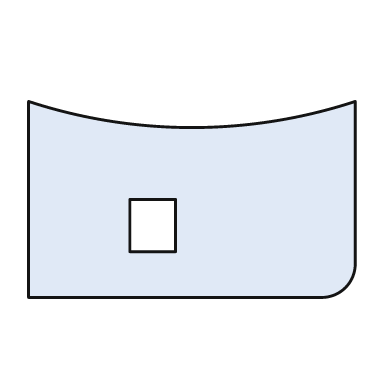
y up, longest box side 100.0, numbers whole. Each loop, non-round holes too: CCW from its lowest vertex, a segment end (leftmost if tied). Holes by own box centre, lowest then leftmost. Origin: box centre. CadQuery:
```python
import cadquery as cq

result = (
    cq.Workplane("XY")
    .moveTo(-50.0, -30.0)
    .lineTo(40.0, -30.0)
    .threePointArc((47.0, -27.0), (50.0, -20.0))
    .lineTo(50.0, 30.0)
    .threePointArc((0.0, 22.0), (-50.0, 30.0))
    .close()
    .moveTo(-19.0, -16.0)
    .lineTo(-5.0, -16.0)
    .lineTo(-5.0, 0.0)
    .lineTo(-19.0, 0.0)
    .close()
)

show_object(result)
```